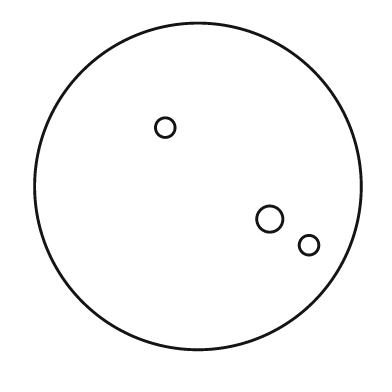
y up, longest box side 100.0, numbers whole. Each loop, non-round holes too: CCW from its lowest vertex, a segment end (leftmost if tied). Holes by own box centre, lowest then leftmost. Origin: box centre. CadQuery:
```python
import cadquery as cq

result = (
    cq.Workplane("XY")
    .moveTo(0.0, 0.0)
    .circle(50.0)
    .moveTo(34.0, -18.0)
    .circle(3.0)
    .moveTo(22.0, -10.0)
    .circle(4.0)
    .moveTo(-10.0, 18.0)
    .circle(3.0)
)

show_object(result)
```